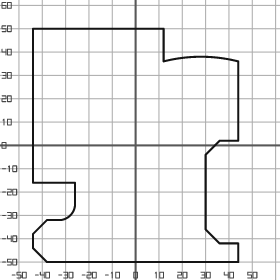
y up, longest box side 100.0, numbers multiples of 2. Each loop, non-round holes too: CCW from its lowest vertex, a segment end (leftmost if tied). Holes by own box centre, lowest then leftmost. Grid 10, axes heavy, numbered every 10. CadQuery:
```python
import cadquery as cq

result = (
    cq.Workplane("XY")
    .moveTo(-38.0, -50.0)
    .lineTo(44.0, -50.0)
    .lineTo(44.0, -42.0)
    .lineTo(36.0, -42.0)
    .lineTo(30.0, -36.0)
    .lineTo(30.0, -4.0)
    .lineTo(36.0, 2.0)
    .lineTo(44.0, 2.0)
    .lineTo(44.0, 36.0)
    .threePointArc((28.0, 38.0), (12.0, 36.0))
    .lineTo(12.0, 50.0)
    .lineTo(-44.0, 50.0)
    .lineTo(-44.0, -16.0)
    .lineTo(-26.0, -16.0)
    .lineTo(-26.0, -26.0)
    .threePointArc((-28.0, -30.0), (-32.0, -32.0))
    .lineTo(-38.0, -32.0)
    .lineTo(-44.0, -38.0)
    .lineTo(-44.0, -44.0)
    .close()
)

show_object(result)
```